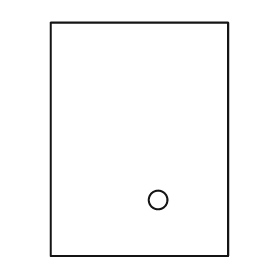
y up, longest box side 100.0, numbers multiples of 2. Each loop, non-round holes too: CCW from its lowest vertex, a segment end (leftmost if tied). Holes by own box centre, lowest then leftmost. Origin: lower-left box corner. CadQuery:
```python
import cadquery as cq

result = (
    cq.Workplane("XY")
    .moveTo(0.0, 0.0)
    .lineTo(76.0, 0.0)
    .lineTo(76.0, 100.0)
    .lineTo(0.0, 100.0)
    .close()
    .moveTo(46.0, 24.0)
    .circle(4.0)
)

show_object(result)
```